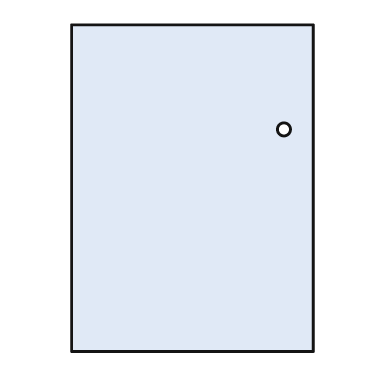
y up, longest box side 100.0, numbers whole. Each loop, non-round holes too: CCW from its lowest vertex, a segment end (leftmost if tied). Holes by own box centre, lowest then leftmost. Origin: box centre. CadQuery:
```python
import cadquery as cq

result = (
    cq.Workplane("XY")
    .moveTo(-37.0, -50.0)
    .lineTo(37.0, -50.0)
    .lineTo(37.0, 50.0)
    .lineTo(-37.0, 50.0)
    .close()
    .moveTo(28.0, 18.0)
    .circle(2.0)
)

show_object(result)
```